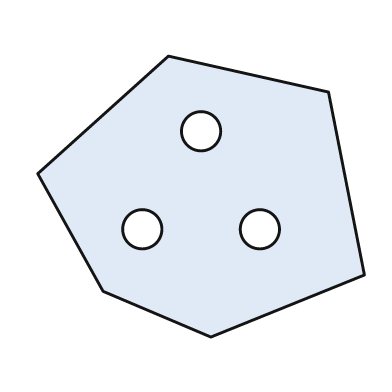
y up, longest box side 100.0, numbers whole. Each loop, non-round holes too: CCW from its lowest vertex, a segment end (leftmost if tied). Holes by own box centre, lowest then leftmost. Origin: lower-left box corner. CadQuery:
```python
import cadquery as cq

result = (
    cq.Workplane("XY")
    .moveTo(53.0, 0.0)
    .lineTo(100.0, 19.0)
    .lineTo(89.0, 75.0)
    .lineTo(40.0, 86.0)
    .lineTo(0.0, 50.0)
    .lineTo(20.0, 14.0)
    .close()
    .moveTo(32.0, 33.0)
    .circle(6.0)
    .moveTo(68.0, 33.0)
    .circle(6.0)
    .moveTo(50.0, 63.0)
    .circle(6.0)
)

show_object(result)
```